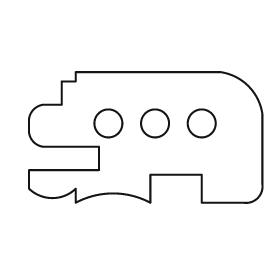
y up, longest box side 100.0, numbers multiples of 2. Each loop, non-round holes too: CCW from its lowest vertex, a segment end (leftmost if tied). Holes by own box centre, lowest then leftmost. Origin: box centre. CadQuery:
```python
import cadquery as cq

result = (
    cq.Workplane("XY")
    .moveTo(-30.0, -28.0)
    .threePointArc((-14.0, -24.0), (2.0, -28.0))
    .lineTo(2.0, -16.0)
    .lineTo(24.0, -16.0)
    .lineTo(24.0, -28.0)
    .lineTo(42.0, -28.0)
    .threePointArc((48.0, -26.0), (50.0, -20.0))
    .lineTo(50.0, 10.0)
    .threePointArc((44.0, 22.0), (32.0, 28.0))
    .lineTo(-30.0, 28.0)
    .lineTo(-30.0, 24.0)
    .lineTo(-36.0, 24.0)
    .lineTo(-36.0, 14.0)
    .lineTo(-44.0, 14.0)
    .threePointArc((-48.0, 12.0), (-50.0, 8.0))
    .lineTo(-50.0, 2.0)
    .threePointArc((-48.0, -2.0), (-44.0, -4.0))
    .lineTo(-20.0, -4.0)
    .lineTo(-20.0, -14.0)
    .lineTo(-50.0, -14.0)
    .lineTo(-50.0, -22.0)
    .threePointArc((-40.0, -26.0), (-30.0, -22.0))
    .close()
    .moveTo(-16.0, 6.0)
    .circle(6.0)
    .moveTo(4.0, 6.0)
    .circle(6.0)
    .moveTo(24.0, 6.0)
    .circle(6.0)
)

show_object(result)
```